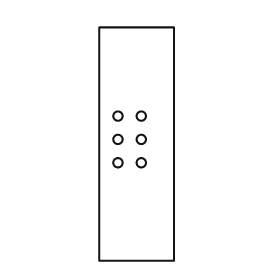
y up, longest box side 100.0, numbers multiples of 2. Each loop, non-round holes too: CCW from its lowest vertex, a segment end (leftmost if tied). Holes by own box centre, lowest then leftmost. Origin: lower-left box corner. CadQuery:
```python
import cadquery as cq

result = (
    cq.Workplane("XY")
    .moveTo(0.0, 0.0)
    .lineTo(32.0, 0.0)
    .lineTo(32.0, 100.0)
    .lineTo(0.0, 100.0)
    .close()
    .moveTo(8.0, 42.0)
    .circle(2.0)
    .moveTo(18.0, 42.0)
    .circle(2.0)
    .moveTo(8.0, 52.0)
    .circle(2.0)
    .moveTo(18.0, 52.0)
    .circle(2.0)
    .moveTo(8.0, 62.0)
    .circle(2.0)
    .moveTo(18.0, 62.0)
    .circle(2.0)
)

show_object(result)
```